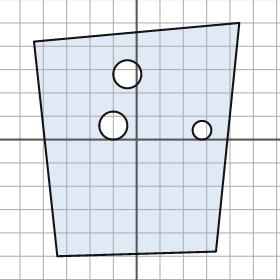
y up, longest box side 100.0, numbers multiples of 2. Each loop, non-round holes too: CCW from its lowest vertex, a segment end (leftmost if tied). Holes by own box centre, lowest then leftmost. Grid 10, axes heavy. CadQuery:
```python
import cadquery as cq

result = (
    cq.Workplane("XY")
    .moveTo(-34.0, -50.0)
    .lineTo(34.0, -48.0)
    .lineTo(44.0, 50.0)
    .lineTo(-44.0, 42.0)
    .close()
    .moveTo(28.0, 4.0)
    .circle(4.0)
    .moveTo(-10.0, 6.0)
    .circle(6.0)
    .moveTo(-4.0, 28.0)
    .circle(6.0)
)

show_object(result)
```